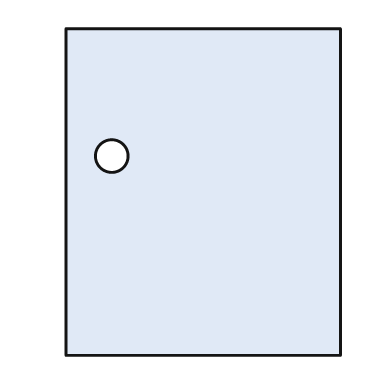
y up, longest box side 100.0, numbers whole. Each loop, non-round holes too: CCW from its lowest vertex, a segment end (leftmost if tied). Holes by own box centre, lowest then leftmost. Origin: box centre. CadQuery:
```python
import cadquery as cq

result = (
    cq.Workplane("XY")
    .moveTo(-42.0, -50.0)
    .lineTo(42.0, -50.0)
    .lineTo(42.0, 50.0)
    .lineTo(-42.0, 50.0)
    .close()
    .moveTo(-28.0, 11.0)
    .circle(5.0)
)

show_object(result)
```